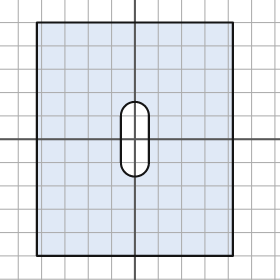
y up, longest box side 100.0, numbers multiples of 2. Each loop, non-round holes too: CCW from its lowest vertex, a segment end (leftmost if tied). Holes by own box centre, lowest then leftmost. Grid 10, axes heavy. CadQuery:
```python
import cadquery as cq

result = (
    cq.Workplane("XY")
    .moveTo(-42.0, -50.0)
    .lineTo(42.0, -50.0)
    .lineTo(42.0, 50.0)
    .lineTo(-42.0, 50.0)
    .close()
    .moveTo(-6.0, -10.0)
    .threePointArc((0.0, -16.0), (6.0, -10.0))
    .lineTo(6.0, 10.0)
    .threePointArc((0.0, 16.0), (-6.0, 10.0))
    .close()
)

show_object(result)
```